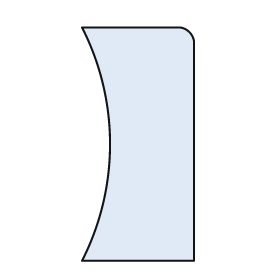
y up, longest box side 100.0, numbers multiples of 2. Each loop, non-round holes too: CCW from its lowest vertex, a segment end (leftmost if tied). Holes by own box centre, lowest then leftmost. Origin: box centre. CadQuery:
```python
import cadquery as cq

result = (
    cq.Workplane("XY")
    .moveTo(-24.0, -50.0)
    .lineTo(24.0, -50.0)
    .lineTo(24.0, 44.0)
    .threePointArc((22.0, 48.0), (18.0, 50.0))
    .lineTo(-24.0, 50.0)
    .threePointArc((-12.0, 0.0), (-24.0, -50.0))
    .close()
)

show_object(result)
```